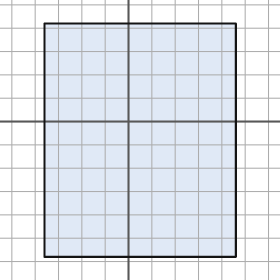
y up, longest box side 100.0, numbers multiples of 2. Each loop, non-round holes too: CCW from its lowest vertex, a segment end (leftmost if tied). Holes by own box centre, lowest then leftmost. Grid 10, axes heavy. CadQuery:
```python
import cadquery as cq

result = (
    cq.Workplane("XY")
    .moveTo(-36.0, -58.0)
    .lineTo(46.0, -58.0)
    .lineTo(46.0, 42.0)
    .lineTo(-36.0, 42.0)
    .close()
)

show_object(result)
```